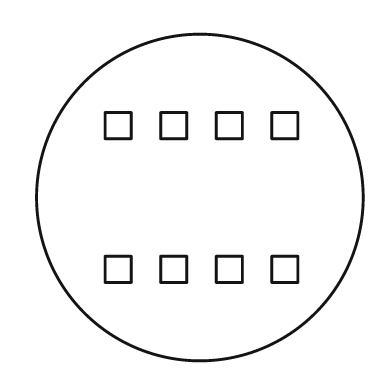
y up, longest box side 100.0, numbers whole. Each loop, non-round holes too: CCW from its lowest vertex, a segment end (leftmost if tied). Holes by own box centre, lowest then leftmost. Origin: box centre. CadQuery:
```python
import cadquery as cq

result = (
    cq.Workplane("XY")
    .moveTo(0.0, 0.0)
    .circle(50.0)
    .moveTo(-29.0, -26.0)
    .lineTo(-21.0, -26.0)
    .lineTo(-21.0, -18.0)
    .lineTo(-29.0, -18.0)
    .close()
    .moveTo(-12.0, -26.0)
    .lineTo(-4.0, -26.0)
    .lineTo(-4.0, -18.0)
    .lineTo(-12.0, -18.0)
    .close()
    .moveTo(5.0, -26.0)
    .lineTo(13.0, -26.0)
    .lineTo(13.0, -18.0)
    .lineTo(5.0, -18.0)
    .close()
    .moveTo(22.0, -26.0)
    .lineTo(30.0, -26.0)
    .lineTo(30.0, -18.0)
    .lineTo(22.0, -18.0)
    .close()
    .moveTo(-29.0, 18.0)
    .lineTo(-21.0, 18.0)
    .lineTo(-21.0, 26.0)
    .lineTo(-29.0, 26.0)
    .close()
    .moveTo(-12.0, 18.0)
    .lineTo(-4.0, 18.0)
    .lineTo(-4.0, 26.0)
    .lineTo(-12.0, 26.0)
    .close()
    .moveTo(5.0, 18.0)
    .lineTo(13.0, 18.0)
    .lineTo(13.0, 26.0)
    .lineTo(5.0, 26.0)
    .close()
    .moveTo(22.0, 18.0)
    .lineTo(30.0, 18.0)
    .lineTo(30.0, 26.0)
    .lineTo(22.0, 26.0)
    .close()
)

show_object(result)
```